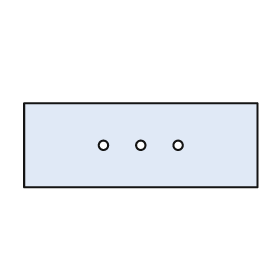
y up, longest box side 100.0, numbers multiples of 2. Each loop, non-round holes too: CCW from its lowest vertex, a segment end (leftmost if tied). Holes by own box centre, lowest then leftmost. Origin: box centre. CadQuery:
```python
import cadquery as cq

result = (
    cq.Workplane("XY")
    .moveTo(-50.0, -18.0)
    .lineTo(50.0, -18.0)
    .lineTo(50.0, 18.0)
    .lineTo(-50.0, 18.0)
    .close()
    .moveTo(-16.0, 0.0)
    .circle(2.0)
    .moveTo(0.0, 0.0)
    .circle(2.0)
    .moveTo(16.0, 0.0)
    .circle(2.0)
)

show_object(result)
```